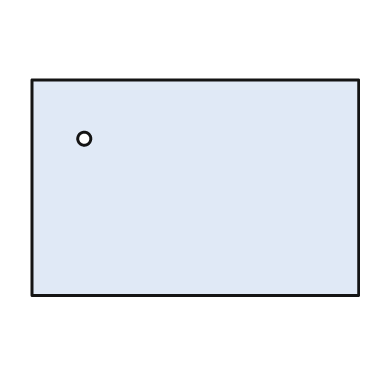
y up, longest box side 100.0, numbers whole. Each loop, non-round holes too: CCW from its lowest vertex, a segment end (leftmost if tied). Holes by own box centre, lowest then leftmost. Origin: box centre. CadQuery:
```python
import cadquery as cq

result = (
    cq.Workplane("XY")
    .moveTo(-50.0, -33.0)
    .lineTo(50.0, -33.0)
    .lineTo(50.0, 33.0)
    .lineTo(-50.0, 33.0)
    .close()
    .moveTo(-34.0, 15.0)
    .circle(2.0)
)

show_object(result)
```